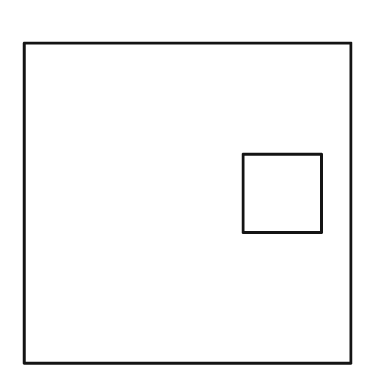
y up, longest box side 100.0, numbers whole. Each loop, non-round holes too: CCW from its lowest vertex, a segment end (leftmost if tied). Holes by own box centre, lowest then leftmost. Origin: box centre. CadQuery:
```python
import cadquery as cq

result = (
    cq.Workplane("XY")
    .moveTo(-50.0, -49.0)
    .lineTo(50.0, -49.0)
    .lineTo(50.0, 49.0)
    .lineTo(-50.0, 49.0)
    .close()
    .moveTo(17.0, -9.0)
    .lineTo(41.0, -9.0)
    .lineTo(41.0, 15.0)
    .lineTo(17.0, 15.0)
    .close()
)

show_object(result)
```